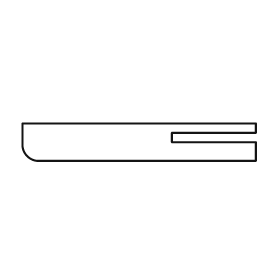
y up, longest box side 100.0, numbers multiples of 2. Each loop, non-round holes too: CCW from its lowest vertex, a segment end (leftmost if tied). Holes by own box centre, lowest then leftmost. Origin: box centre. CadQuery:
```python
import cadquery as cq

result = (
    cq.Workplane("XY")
    .moveTo(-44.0, -8.0)
    .lineTo(50.0, -8.0)
    .lineTo(50.0, 0.0)
    .lineTo(14.0, 0.0)
    .lineTo(14.0, 4.0)
    .lineTo(50.0, 4.0)
    .lineTo(50.0, 8.0)
    .lineTo(-50.0, 8.0)
    .lineTo(-50.0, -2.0)
    .threePointArc((-48.0, -6.0), (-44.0, -8.0))
    .close()
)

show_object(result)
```